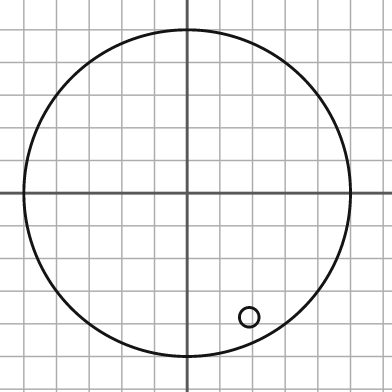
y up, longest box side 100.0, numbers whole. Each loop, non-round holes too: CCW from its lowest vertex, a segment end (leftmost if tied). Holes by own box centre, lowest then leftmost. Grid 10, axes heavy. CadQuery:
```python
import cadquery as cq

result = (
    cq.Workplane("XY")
    .moveTo(0.0, 0.0)
    .circle(50.0)
    .moveTo(19.0, -38.0)
    .circle(3.0)
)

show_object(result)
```